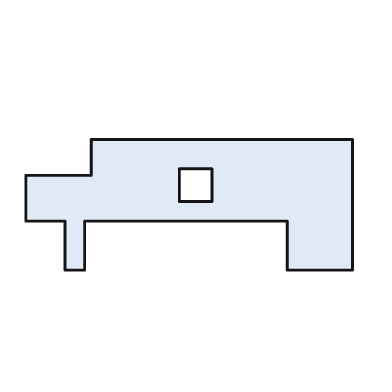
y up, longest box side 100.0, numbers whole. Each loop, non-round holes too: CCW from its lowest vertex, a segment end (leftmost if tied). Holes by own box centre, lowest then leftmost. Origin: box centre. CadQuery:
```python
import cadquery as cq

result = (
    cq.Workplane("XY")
    .moveTo(-38.0, -20.0)
    .lineTo(-32.0, -20.0)
    .lineTo(-32.0, -5.0)
    .lineTo(30.0, -5.0)
    .lineTo(30.0, -20.0)
    .lineTo(50.0, -20.0)
    .lineTo(50.0, 20.0)
    .lineTo(-30.0, 20.0)
    .lineTo(-30.0, 9.0)
    .lineTo(-50.0, 9.0)
    .lineTo(-50.0, -5.0)
    .lineTo(-38.0, -5.0)
    .close()
    .moveTo(-3.0, 1.0)
    .lineTo(7.0, 1.0)
    .lineTo(7.0, 11.0)
    .lineTo(-3.0, 11.0)
    .close()
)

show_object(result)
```